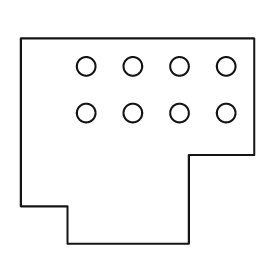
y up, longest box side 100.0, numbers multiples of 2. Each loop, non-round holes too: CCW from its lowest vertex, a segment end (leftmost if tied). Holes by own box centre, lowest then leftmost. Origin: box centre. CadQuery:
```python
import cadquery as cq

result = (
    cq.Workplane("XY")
    .moveTo(-30.0, -44.0)
    .lineTo(22.0, -44.0)
    .lineTo(22.0, -6.0)
    .lineTo(50.0, -6.0)
    .lineTo(50.0, 44.0)
    .lineTo(-50.0, 44.0)
    .lineTo(-50.0, -28.0)
    .lineTo(-30.0, -28.0)
    .close()
    .moveTo(-22.0, 12.0)
    .circle(4.0)
    .moveTo(-2.0, 12.0)
    .circle(4.0)
    .moveTo(18.0, 12.0)
    .circle(4.0)
    .moveTo(38.0, 12.0)
    .circle(4.0)
    .moveTo(-22.0, 32.0)
    .circle(4.0)
    .moveTo(-2.0, 32.0)
    .circle(4.0)
    .moveTo(18.0, 32.0)
    .circle(4.0)
    .moveTo(38.0, 32.0)
    .circle(4.0)
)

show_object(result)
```